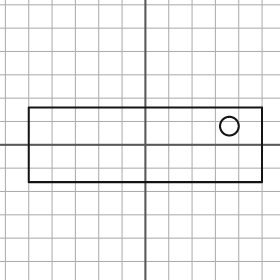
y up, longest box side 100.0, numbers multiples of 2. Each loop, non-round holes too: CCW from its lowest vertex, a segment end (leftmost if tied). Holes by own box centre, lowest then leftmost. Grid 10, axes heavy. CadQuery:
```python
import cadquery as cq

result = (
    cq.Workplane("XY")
    .moveTo(-50.0, -16.0)
    .lineTo(50.0, -16.0)
    .lineTo(50.0, 16.0)
    .lineTo(-50.0, 16.0)
    .close()
    .moveTo(36.0, 8.0)
    .circle(4.0)
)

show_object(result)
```